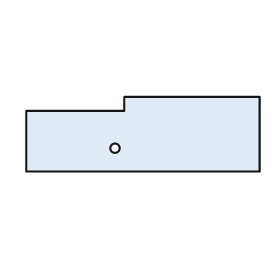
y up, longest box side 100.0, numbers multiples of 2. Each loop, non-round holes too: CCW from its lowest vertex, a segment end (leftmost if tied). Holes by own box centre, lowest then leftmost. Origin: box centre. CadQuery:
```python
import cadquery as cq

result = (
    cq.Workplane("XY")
    .moveTo(-50.0, -16.0)
    .lineTo(50.0, -16.0)
    .lineTo(50.0, 16.0)
    .lineTo(-8.0, 16.0)
    .lineTo(-8.0, 10.0)
    .lineTo(-50.0, 10.0)
    .close()
    .moveTo(-12.0, -6.0)
    .circle(2.0)
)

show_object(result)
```